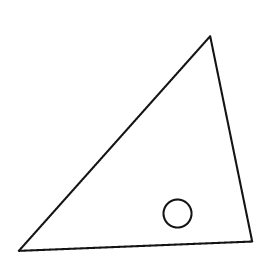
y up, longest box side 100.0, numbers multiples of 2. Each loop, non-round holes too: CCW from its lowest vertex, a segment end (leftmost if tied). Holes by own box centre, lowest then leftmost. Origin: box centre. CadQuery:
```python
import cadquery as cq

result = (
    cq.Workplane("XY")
    .moveTo(-50.0, -46.0)
    .lineTo(50.0, -42.0)
    .lineTo(32.0, 46.0)
    .close()
    .moveTo(18.0, -30.0)
    .circle(6.0)
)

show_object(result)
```